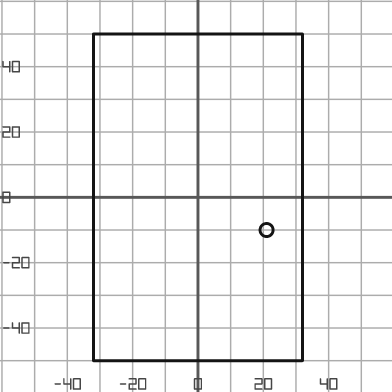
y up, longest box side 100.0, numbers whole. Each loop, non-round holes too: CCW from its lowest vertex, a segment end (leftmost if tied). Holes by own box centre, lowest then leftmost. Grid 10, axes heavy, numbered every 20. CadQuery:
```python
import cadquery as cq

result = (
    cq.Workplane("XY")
    .moveTo(-32.0, -50.0)
    .lineTo(32.0, -50.0)
    .lineTo(32.0, 50.0)
    .lineTo(-32.0, 50.0)
    .close()
    .moveTo(21.0, -10.0)
    .circle(2.0)
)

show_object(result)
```